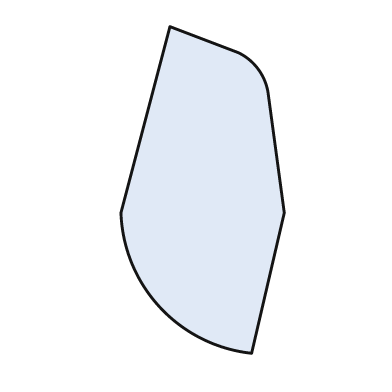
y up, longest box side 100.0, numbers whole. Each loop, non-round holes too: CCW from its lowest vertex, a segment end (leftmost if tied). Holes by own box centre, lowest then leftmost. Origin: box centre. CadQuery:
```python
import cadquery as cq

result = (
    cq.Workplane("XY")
    .moveTo(15.0, -50.0)
    .lineTo(25.0, -7.0)
    .lineTo(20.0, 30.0)
    .threePointArc((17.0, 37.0), (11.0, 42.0))
    .lineTo(-10.0, 50.0)
    .lineTo(-25.0, -7.0)
    .threePointArc((-13.0, -36.0), (15.0, -50.0))
    .close()
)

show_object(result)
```